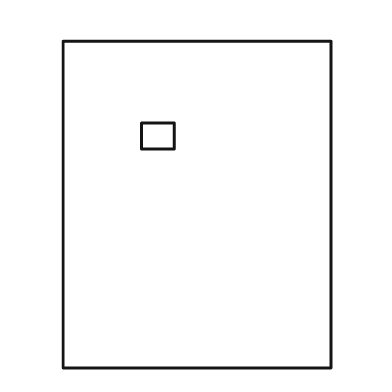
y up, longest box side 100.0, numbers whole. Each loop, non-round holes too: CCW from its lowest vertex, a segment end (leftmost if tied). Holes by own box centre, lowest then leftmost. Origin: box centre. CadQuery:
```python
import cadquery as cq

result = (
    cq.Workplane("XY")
    .moveTo(-41.0, -50.0)
    .lineTo(41.0, -50.0)
    .lineTo(41.0, 50.0)
    .lineTo(-41.0, 50.0)
    .close()
    .moveTo(-17.0, 17.0)
    .lineTo(-7.0, 17.0)
    .lineTo(-7.0, 25.0)
    .lineTo(-17.0, 25.0)
    .close()
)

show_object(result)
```